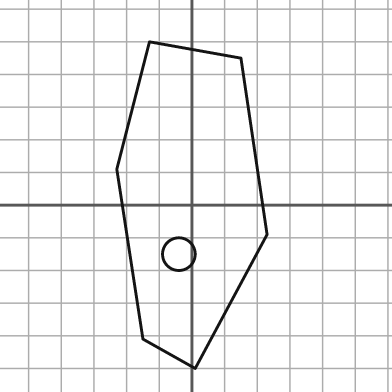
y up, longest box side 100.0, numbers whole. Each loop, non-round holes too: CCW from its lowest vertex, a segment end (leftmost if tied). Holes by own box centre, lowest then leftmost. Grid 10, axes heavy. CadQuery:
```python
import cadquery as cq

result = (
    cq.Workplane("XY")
    .moveTo(1.0, -50.0)
    .lineTo(23.0, -9.0)
    .lineTo(15.0, 45.0)
    .lineTo(-13.0, 50.0)
    .lineTo(-23.0, 11.0)
    .lineTo(-15.0, -41.0)
    .close()
    .moveTo(-4.0, -15.0)
    .circle(5.0)
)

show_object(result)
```